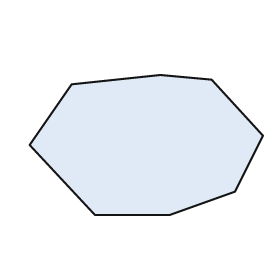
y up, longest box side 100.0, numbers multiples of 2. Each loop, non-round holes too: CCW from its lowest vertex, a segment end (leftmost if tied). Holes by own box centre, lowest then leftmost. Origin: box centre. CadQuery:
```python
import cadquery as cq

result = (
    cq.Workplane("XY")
    .moveTo(-22.0, -30.0)
    .lineTo(10.0, -30.0)
    .lineTo(38.0, -20.0)
    .lineTo(50.0, 4.0)
    .lineTo(28.0, 28.0)
    .lineTo(6.0, 30.0)
    .lineTo(-32.0, 26.0)
    .lineTo(-50.0, 0.0)
    .close()
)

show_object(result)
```